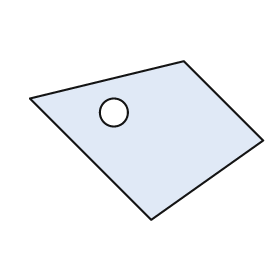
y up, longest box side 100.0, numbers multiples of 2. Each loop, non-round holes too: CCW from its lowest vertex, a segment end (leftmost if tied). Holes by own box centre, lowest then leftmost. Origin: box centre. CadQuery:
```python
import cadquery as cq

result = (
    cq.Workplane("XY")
    .moveTo(2.0, -34.0)
    .lineTo(50.0, 0.0)
    .lineTo(16.0, 34.0)
    .lineTo(-50.0, 18.0)
    .close()
    .moveTo(-14.0, 12.0)
    .circle(6.0)
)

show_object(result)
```